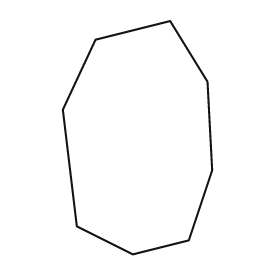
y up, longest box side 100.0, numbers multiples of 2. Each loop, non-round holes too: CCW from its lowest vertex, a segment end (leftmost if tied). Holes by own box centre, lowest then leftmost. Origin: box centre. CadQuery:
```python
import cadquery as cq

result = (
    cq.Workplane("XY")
    .moveTo(-2.0, -50.0)
    .lineTo(22.0, -44.0)
    .lineTo(32.0, -14.0)
    .lineTo(30.0, 24.0)
    .lineTo(14.0, 50.0)
    .lineTo(-18.0, 42.0)
    .lineTo(-32.0, 12.0)
    .lineTo(-26.0, -38.0)
    .close()
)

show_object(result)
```